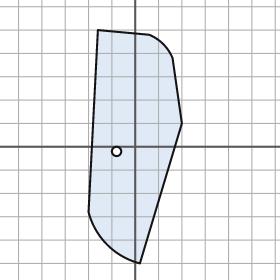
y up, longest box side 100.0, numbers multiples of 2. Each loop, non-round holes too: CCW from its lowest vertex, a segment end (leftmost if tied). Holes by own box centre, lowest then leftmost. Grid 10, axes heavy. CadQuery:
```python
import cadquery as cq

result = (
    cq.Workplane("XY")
    .moveTo(2.0, -50.0)
    .lineTo(20.0, 10.0)
    .lineTo(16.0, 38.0)
    .threePointArc((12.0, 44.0), (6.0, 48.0))
    .lineTo(-16.0, 50.0)
    .lineTo(-20.0, -28.0)
    .threePointArc((-12.0, -42.0), (2.0, -50.0))
    .close()
    .moveTo(-8.0, -2.0)
    .circle(2.0)
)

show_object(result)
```